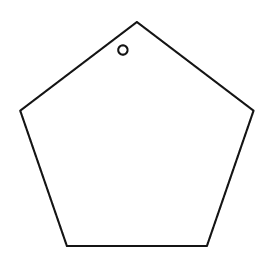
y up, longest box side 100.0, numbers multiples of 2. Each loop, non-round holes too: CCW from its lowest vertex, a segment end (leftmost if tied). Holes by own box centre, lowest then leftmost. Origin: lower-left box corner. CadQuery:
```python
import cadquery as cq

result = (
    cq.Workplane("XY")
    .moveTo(20.0, 0.0)
    .lineTo(80.0, 0.0)
    .lineTo(100.0, 58.0)
    .lineTo(50.0, 96.0)
    .lineTo(0.0, 58.0)
    .close()
    .moveTo(44.0, 84.0)
    .circle(2.0)
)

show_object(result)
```